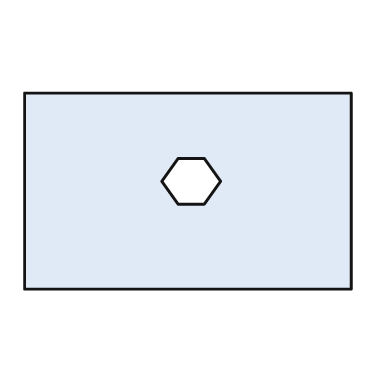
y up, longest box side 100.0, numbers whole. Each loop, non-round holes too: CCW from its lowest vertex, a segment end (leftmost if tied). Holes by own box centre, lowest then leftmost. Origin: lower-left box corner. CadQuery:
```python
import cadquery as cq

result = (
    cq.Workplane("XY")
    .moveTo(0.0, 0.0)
    .lineTo(100.0, 0.0)
    .lineTo(100.0, 60.0)
    .lineTo(0.0, 60.0)
    .close()
    .moveTo(47.0, 26.0)
    .lineTo(55.0, 26.0)
    .lineTo(60.0, 33.0)
    .lineTo(55.0, 40.0)
    .lineTo(47.0, 40.0)
    .lineTo(42.0, 33.0)
    .close()
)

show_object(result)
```